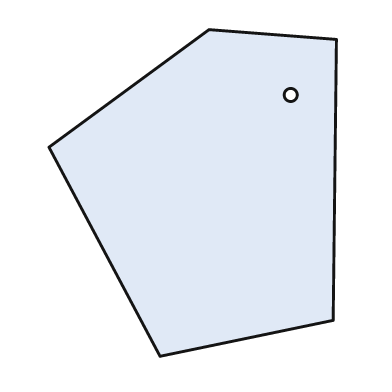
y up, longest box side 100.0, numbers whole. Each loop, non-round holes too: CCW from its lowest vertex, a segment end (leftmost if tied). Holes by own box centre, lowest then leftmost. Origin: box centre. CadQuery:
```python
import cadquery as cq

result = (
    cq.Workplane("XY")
    .moveTo(-10.0, -50.0)
    .lineTo(43.0, -39.0)
    .lineTo(44.0, 47.0)
    .lineTo(5.0, 50.0)
    .lineTo(-44.0, 14.0)
    .close()
    .moveTo(30.0, 30.0)
    .circle(2.0)
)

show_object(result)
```